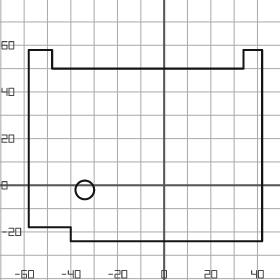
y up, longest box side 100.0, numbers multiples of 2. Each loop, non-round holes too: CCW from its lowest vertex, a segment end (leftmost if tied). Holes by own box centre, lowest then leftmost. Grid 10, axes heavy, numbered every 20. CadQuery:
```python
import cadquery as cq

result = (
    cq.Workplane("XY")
    .moveTo(-40.0, -24.0)
    .lineTo(42.0, -24.0)
    .lineTo(42.0, 58.0)
    .lineTo(34.0, 58.0)
    .lineTo(34.0, 50.0)
    .lineTo(-48.0, 50.0)
    .lineTo(-48.0, 58.0)
    .lineTo(-58.0, 58.0)
    .lineTo(-58.0, -18.0)
    .lineTo(-40.0, -18.0)
    .close()
    .moveTo(-34.0, -2.0)
    .circle(4.0)
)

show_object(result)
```